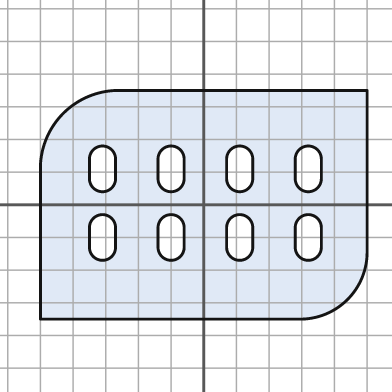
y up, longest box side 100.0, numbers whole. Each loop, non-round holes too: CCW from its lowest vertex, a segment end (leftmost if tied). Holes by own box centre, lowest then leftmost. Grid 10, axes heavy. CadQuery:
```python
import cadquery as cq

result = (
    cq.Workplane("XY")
    .moveTo(-50.0, -35.0)
    .lineTo(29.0, -35.0)
    .threePointArc((44.0, -29.0), (50.0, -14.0))
    .lineTo(50.0, 35.0)
    .lineTo(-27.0, 35.0)
    .threePointArc((-43.0, 28.0), (-50.0, 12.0))
    .close()
    .moveTo(-35.0, -13.0)
    .threePointArc((-31.0, -17.0), (-27.0, -13.0))
    .lineTo(-27.0, -7.0)
    .threePointArc((-31.0, -3.0), (-35.0, -7.0))
    .close()
    .moveTo(-14.0, -13.0)
    .threePointArc((-10.0, -17.0), (-6.0, -13.0))
    .lineTo(-6.0, -7.0)
    .threePointArc((-10.0, -3.0), (-14.0, -7.0))
    .close()
    .moveTo(7.0, -13.0)
    .threePointArc((11.0, -17.0), (15.0, -13.0))
    .lineTo(15.0, -7.0)
    .threePointArc((11.0, -3.0), (7.0, -7.0))
    .close()
    .moveTo(28.0, -13.0)
    .threePointArc((32.0, -17.0), (36.0, -13.0))
    .lineTo(36.0, -7.0)
    .threePointArc((32.0, -3.0), (28.0, -7.0))
    .close()
    .moveTo(-35.0, 8.0)
    .threePointArc((-31.0, 4.0), (-27.0, 8.0))
    .lineTo(-27.0, 14.0)
    .threePointArc((-31.0, 18.0), (-35.0, 14.0))
    .close()
    .moveTo(-14.0, 8.0)
    .threePointArc((-10.0, 4.0), (-6.0, 8.0))
    .lineTo(-6.0, 14.0)
    .threePointArc((-10.0, 18.0), (-14.0, 14.0))
    .close()
    .moveTo(7.0, 8.0)
    .threePointArc((11.0, 4.0), (15.0, 8.0))
    .lineTo(15.0, 14.0)
    .threePointArc((11.0, 18.0), (7.0, 14.0))
    .close()
    .moveTo(28.0, 8.0)
    .threePointArc((32.0, 4.0), (36.0, 8.0))
    .lineTo(36.0, 14.0)
    .threePointArc((32.0, 18.0), (28.0, 14.0))
    .close()
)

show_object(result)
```